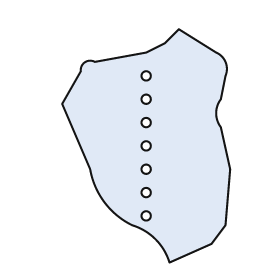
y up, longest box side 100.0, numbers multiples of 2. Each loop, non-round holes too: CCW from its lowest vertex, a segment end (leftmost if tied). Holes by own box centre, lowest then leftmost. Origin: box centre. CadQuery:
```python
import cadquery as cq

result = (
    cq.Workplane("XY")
    .moveTo(10.0, -50.0)
    .lineTo(28.0, -42.0)
    .lineTo(34.0, -34.0)
    .lineTo(36.0, -10.0)
    .lineTo(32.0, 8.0)
    .threePointArc((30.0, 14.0), (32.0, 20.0))
    .lineTo(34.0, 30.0)
    .threePointArc((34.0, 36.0), (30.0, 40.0))
    .lineTo(14.0, 50.0)
    .lineTo(8.0, 44.0)
    .lineTo(0.0, 40.0)
    .lineTo(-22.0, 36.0)
    .threePointArc((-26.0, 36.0), (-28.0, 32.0))
    .lineTo(-36.0, 18.0)
    .lineTo(-24.0, -10.0)
    .threePointArc((-18.0, -24.0), (-6.0, -34.0))
    .threePointArc((4.0, -40.0), (10.0, -50.0))
    .close()
    .moveTo(0.0, -30.0)
    .circle(2.0)
    .moveTo(0.0, -20.0)
    .circle(2.0)
    .moveTo(0.0, -10.0)
    .circle(2.0)
    .moveTo(0.0, 0.0)
    .circle(2.0)
    .moveTo(0.0, 10.0)
    .circle(2.0)
    .moveTo(0.0, 20.0)
    .circle(2.0)
    .moveTo(0.0, 30.0)
    .circle(2.0)
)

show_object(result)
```